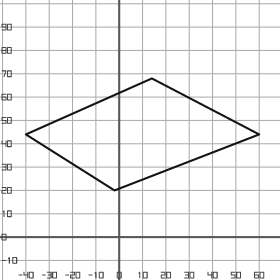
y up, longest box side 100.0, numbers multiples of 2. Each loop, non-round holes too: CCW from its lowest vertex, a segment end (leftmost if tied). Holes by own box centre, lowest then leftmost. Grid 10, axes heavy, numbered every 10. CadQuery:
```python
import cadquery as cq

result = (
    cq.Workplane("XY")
    .moveTo(-2.0, 20.0)
    .lineTo(60.0, 44.0)
    .lineTo(14.0, 68.0)
    .lineTo(-40.0, 44.0)
    .close()
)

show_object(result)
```